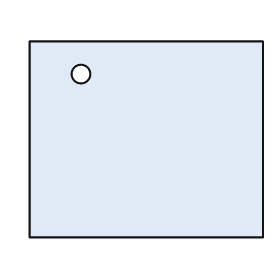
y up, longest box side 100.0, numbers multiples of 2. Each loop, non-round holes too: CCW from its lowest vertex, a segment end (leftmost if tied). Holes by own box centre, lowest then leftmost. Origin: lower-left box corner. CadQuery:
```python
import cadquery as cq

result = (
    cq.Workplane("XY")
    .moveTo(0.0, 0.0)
    .lineTo(100.0, 0.0)
    .lineTo(100.0, 84.0)
    .lineTo(0.0, 84.0)
    .close()
    .moveTo(22.0, 70.0)
    .circle(4.0)
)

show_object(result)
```